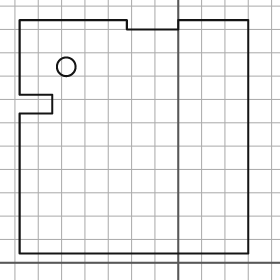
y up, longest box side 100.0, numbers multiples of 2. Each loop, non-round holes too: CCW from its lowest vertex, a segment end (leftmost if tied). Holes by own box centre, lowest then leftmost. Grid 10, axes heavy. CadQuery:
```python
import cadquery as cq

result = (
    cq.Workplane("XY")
    .moveTo(-68.0, 4.0)
    .lineTo(30.0, 4.0)
    .lineTo(30.0, 104.0)
    .lineTo(0.0, 104.0)
    .lineTo(0.0, 100.0)
    .lineTo(-22.0, 100.0)
    .lineTo(-22.0, 104.0)
    .lineTo(-68.0, 104.0)
    .lineTo(-68.0, 72.0)
    .lineTo(-54.0, 72.0)
    .lineTo(-54.0, 64.0)
    .lineTo(-68.0, 64.0)
    .close()
    .moveTo(-48.0, 84.0)
    .circle(4.0)
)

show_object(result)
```